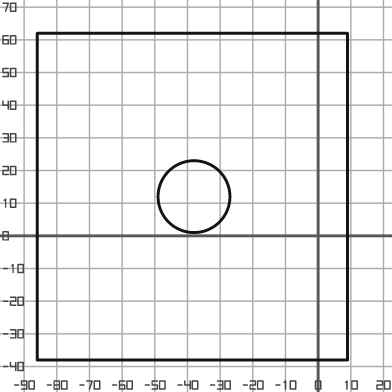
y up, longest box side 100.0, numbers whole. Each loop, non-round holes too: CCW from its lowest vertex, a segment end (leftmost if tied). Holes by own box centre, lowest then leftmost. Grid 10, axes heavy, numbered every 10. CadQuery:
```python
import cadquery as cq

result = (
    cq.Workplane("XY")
    .moveTo(-86.0, -38.0)
    .lineTo(9.0, -38.0)
    .lineTo(9.0, 62.0)
    .lineTo(-86.0, 62.0)
    .close()
    .moveTo(-38.0, 12.0)
    .circle(11.0)
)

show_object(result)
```